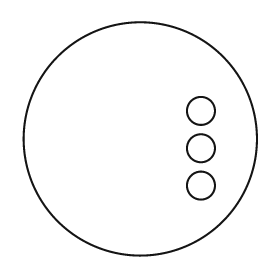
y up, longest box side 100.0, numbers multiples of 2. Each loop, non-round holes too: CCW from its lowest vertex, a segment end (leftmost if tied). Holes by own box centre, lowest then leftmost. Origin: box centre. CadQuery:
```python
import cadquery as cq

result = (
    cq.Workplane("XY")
    .moveTo(0.0, 0.0)
    .circle(50.0)
    .moveTo(26.0, -20.0)
    .circle(6.0)
    .moveTo(26.0, -4.0)
    .circle(6.0)
    .moveTo(26.0, 12.0)
    .circle(6.0)
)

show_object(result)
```